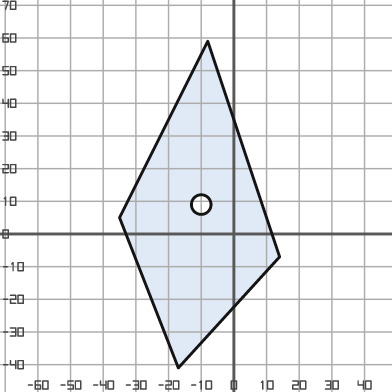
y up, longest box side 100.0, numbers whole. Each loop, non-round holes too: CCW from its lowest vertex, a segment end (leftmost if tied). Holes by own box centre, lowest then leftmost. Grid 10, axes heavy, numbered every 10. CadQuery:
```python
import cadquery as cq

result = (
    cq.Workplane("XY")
    .moveTo(-17.0, -41.0)
    .lineTo(14.0, -7.0)
    .lineTo(-8.0, 59.0)
    .lineTo(-35.0, 5.0)
    .close()
    .moveTo(-10.0, 9.0)
    .circle(3.0)
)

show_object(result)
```